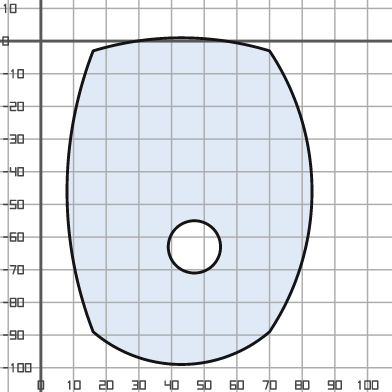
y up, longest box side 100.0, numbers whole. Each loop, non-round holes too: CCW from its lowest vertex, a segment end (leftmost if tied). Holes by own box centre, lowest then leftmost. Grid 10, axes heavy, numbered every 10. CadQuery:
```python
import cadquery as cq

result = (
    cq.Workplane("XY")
    .moveTo(16.0, -89.0)
    .threePointArc((43.0, -99.0), (70.0, -89.0))
    .threePointArc((83.0, -46.0), (70.0, -3.0))
    .threePointArc((43.0, 1.0), (16.0, -3.0))
    .threePointArc((8.0, -46.0), (16.0, -89.0))
    .close()
    .moveTo(47.0, -63.0)
    .circle(8.0)
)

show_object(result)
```